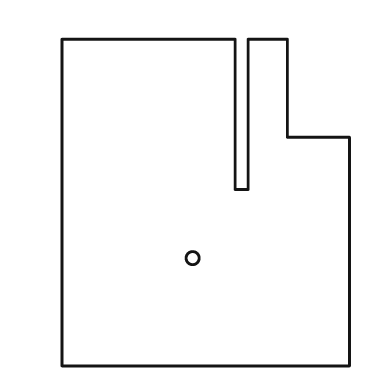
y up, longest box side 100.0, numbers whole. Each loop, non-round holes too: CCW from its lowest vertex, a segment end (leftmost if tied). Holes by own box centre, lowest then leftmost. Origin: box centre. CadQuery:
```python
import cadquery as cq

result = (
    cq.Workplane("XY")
    .moveTo(-44.0, -50.0)
    .lineTo(44.0, -50.0)
    .lineTo(44.0, 20.0)
    .lineTo(25.0, 20.0)
    .lineTo(25.0, 50.0)
    .lineTo(13.0, 50.0)
    .lineTo(13.0, 4.0)
    .lineTo(9.0, 4.0)
    .lineTo(9.0, 50.0)
    .lineTo(-44.0, 50.0)
    .close()
    .moveTo(-4.0, -17.0)
    .circle(2.0)
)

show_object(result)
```